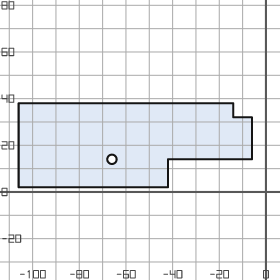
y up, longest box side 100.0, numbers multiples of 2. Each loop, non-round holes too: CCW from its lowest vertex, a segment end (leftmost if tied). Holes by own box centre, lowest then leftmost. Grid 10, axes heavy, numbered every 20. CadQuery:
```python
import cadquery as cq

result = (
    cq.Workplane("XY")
    .moveTo(-106.0, 2.0)
    .lineTo(-42.0, 2.0)
    .lineTo(-42.0, 14.0)
    .lineTo(-6.0, 14.0)
    .lineTo(-6.0, 32.0)
    .lineTo(-14.0, 32.0)
    .lineTo(-14.0, 38.0)
    .lineTo(-106.0, 38.0)
    .close()
    .moveTo(-66.0, 14.0)
    .circle(2.0)
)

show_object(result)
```